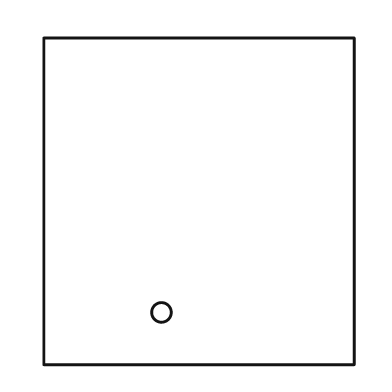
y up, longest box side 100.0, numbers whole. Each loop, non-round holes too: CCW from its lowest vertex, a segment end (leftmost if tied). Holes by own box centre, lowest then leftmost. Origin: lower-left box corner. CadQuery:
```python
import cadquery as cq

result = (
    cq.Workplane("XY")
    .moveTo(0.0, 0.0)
    .lineTo(95.0, 0.0)
    .lineTo(95.0, 100.0)
    .lineTo(0.0, 100.0)
    .close()
    .moveTo(36.0, 16.0)
    .circle(3.0)
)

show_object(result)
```